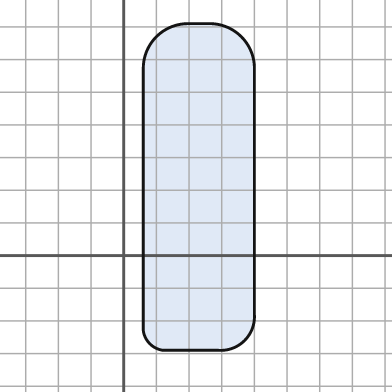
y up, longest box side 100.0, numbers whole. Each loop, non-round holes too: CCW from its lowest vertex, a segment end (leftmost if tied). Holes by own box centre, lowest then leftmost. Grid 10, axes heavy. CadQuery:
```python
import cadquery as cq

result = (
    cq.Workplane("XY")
    .moveTo(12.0, -29.0)
    .lineTo(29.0, -29.0)
    .threePointArc((37.0, -26.0), (40.0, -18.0))
    .lineTo(40.0, 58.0)
    .threePointArc((36.0, 67.0), (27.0, 71.0))
    .lineTo(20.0, 71.0)
    .threePointArc((10.0, 67.0), (6.0, 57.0))
    .lineTo(6.0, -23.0)
    .threePointArc((8.0, -27.0), (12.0, -29.0))
    .close()
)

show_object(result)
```